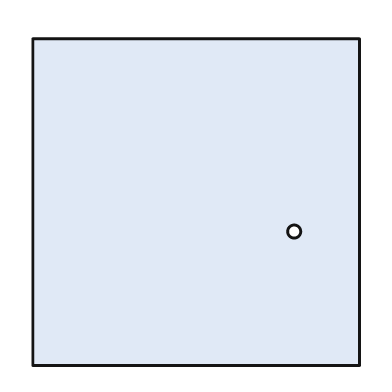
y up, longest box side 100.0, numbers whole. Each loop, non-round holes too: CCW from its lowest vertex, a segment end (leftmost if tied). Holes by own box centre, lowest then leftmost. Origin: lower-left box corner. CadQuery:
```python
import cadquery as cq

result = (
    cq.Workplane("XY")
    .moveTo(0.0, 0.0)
    .lineTo(100.0, 0.0)
    .lineTo(100.0, 100.0)
    .lineTo(0.0, 100.0)
    .close()
    .moveTo(80.0, 41.0)
    .circle(2.0)
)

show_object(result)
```